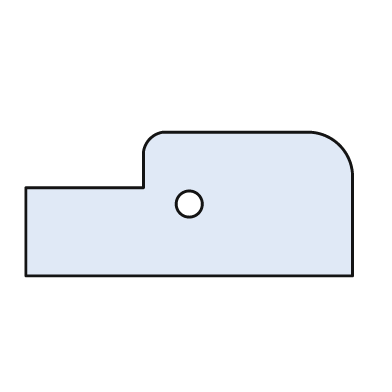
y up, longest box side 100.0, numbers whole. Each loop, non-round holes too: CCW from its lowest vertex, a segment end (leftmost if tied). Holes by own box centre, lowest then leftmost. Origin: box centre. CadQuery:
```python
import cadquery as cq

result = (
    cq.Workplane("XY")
    .moveTo(-50.0, -22.0)
    .lineTo(50.0, -22.0)
    .lineTo(50.0, 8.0)
    .threePointArc((46.0, 18.0), (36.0, 22.0))
    .lineTo(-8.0, 22.0)
    .threePointArc((-12.0, 20.0), (-14.0, 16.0))
    .lineTo(-14.0, 5.0)
    .lineTo(-50.0, 5.0)
    .close()
    .moveTo(0.0, 0.0)
    .circle(4.0)
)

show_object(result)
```